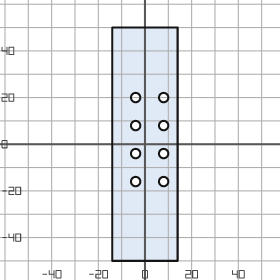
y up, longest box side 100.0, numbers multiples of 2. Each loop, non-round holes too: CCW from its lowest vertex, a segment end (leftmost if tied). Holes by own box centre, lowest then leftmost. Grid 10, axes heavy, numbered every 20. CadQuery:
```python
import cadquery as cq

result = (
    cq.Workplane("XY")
    .moveTo(-14.0, -50.0)
    .lineTo(14.0, -50.0)
    .lineTo(14.0, 50.0)
    .lineTo(-14.0, 50.0)
    .close()
    .moveTo(-4.0, -16.0)
    .circle(2.0)
    .moveTo(8.0, -16.0)
    .circle(2.0)
    .moveTo(-4.0, -4.0)
    .circle(2.0)
    .moveTo(8.0, -4.0)
    .circle(2.0)
    .moveTo(-4.0, 8.0)
    .circle(2.0)
    .moveTo(8.0, 8.0)
    .circle(2.0)
    .moveTo(-4.0, 20.0)
    .circle(2.0)
    .moveTo(8.0, 20.0)
    .circle(2.0)
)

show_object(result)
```